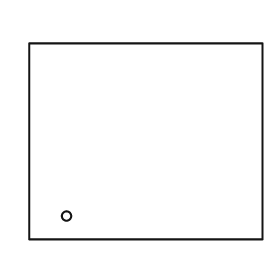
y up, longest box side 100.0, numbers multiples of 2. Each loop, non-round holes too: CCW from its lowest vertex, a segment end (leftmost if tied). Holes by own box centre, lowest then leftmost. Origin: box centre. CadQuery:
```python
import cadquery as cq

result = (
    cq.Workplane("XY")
    .moveTo(-50.0, -42.0)
    .lineTo(50.0, -42.0)
    .lineTo(50.0, 42.0)
    .lineTo(-50.0, 42.0)
    .close()
    .moveTo(-34.0, -32.0)
    .circle(2.0)
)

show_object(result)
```